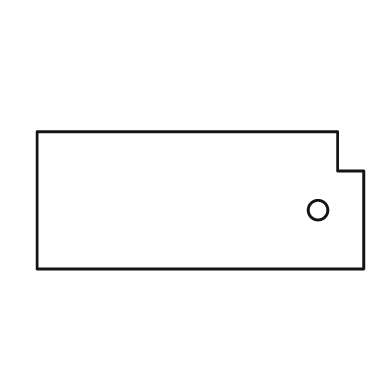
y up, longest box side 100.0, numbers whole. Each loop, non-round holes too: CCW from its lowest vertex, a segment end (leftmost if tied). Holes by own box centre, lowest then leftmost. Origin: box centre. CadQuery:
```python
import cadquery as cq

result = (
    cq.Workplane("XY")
    .moveTo(-50.0, -21.0)
    .lineTo(50.0, -21.0)
    .lineTo(50.0, 9.0)
    .lineTo(42.0, 9.0)
    .lineTo(42.0, 21.0)
    .lineTo(-50.0, 21.0)
    .close()
    .moveTo(36.0, -3.0)
    .circle(3.0)
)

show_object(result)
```